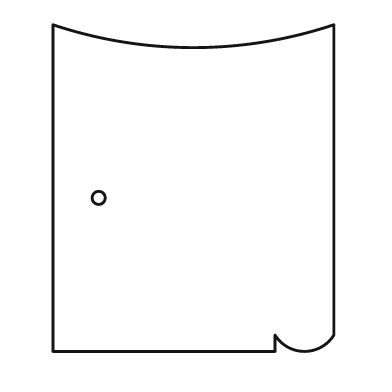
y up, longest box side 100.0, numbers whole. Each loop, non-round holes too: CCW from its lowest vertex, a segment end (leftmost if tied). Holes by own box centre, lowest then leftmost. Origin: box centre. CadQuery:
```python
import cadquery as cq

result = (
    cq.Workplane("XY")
    .moveTo(-43.0, -50.0)
    .lineTo(25.0, -50.0)
    .lineTo(25.0, -45.0)
    .threePointArc((34.0, -50.0), (43.0, -45.0))
    .lineTo(43.0, 50.0)
    .threePointArc((0.0, 43.0), (-43.0, 50.0))
    .close()
    .moveTo(-29.0, -3.0)
    .circle(2.0)
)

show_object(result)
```